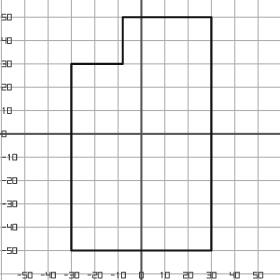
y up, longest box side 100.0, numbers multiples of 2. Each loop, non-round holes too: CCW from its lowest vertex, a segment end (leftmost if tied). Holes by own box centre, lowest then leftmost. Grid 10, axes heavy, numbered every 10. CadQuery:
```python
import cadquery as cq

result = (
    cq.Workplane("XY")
    .moveTo(-30.0, -50.0)
    .lineTo(30.0, -50.0)
    .lineTo(30.0, 50.0)
    .lineTo(-8.0, 50.0)
    .lineTo(-8.0, 30.0)
    .lineTo(-30.0, 30.0)
    .close()
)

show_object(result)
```